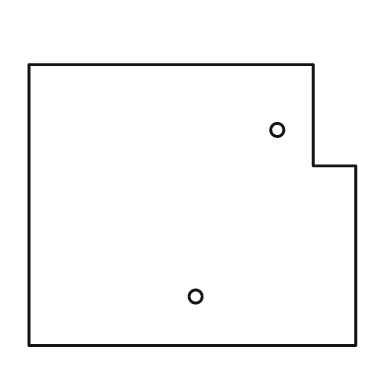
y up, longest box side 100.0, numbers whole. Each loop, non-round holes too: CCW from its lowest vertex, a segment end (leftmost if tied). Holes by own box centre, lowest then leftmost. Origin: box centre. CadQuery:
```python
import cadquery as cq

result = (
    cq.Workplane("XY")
    .moveTo(-50.0, -43.0)
    .lineTo(50.0, -43.0)
    .lineTo(50.0, 12.0)
    .lineTo(37.0, 12.0)
    .lineTo(37.0, 43.0)
    .lineTo(-50.0, 43.0)
    .close()
    .moveTo(1.0, -28.0)
    .circle(2.0)
    .moveTo(26.0, 23.0)
    .circle(2.0)
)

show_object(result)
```